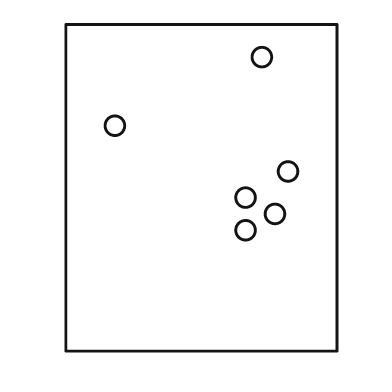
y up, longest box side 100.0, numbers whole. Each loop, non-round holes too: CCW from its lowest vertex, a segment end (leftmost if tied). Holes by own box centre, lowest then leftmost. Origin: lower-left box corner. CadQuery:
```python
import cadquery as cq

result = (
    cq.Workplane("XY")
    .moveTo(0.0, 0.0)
    .lineTo(83.0, 0.0)
    .lineTo(83.0, 100.0)
    .lineTo(0.0, 100.0)
    .close()
    .moveTo(55.0, 37.0)
    .circle(3.0)
    .moveTo(64.0, 42.0)
    .circle(3.0)
    .moveTo(55.0, 47.0)
    .circle(3.0)
    .moveTo(68.0, 55.0)
    .circle(3.0)
    .moveTo(15.0, 69.0)
    .circle(3.0)
    .moveTo(60.0, 90.0)
    .circle(3.0)
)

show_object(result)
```